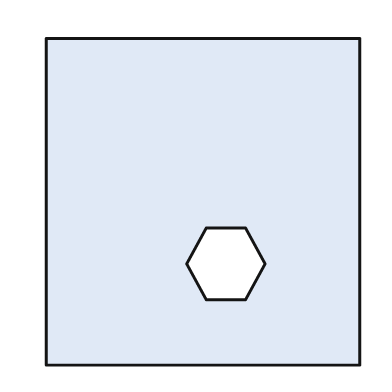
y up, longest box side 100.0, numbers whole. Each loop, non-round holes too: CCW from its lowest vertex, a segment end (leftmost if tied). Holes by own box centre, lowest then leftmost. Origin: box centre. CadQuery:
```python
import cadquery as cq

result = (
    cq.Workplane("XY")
    .moveTo(-48.0, -50.0)
    .lineTo(48.0, -50.0)
    .lineTo(48.0, 50.0)
    .lineTo(-48.0, 50.0)
    .close()
    .moveTo(1.0, -30.0)
    .lineTo(13.0, -30.0)
    .lineTo(19.0, -19.0)
    .lineTo(13.0, -8.0)
    .lineTo(1.0, -8.0)
    .lineTo(-5.0, -19.0)
    .close()
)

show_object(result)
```